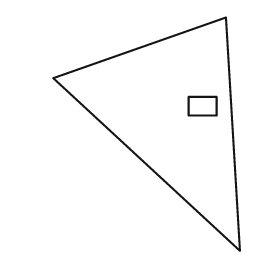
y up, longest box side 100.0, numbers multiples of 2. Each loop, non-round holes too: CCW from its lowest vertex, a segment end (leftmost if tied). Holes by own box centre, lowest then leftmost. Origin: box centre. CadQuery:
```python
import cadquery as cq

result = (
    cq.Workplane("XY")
    .moveTo(40.0, -50.0)
    .lineTo(34.0, 50.0)
    .lineTo(-40.0, 24.0)
    .close()
    .moveTo(18.0, 8.0)
    .lineTo(30.0, 8.0)
    .lineTo(30.0, 16.0)
    .lineTo(18.0, 16.0)
    .close()
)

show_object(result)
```